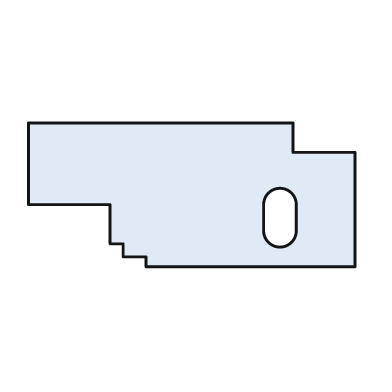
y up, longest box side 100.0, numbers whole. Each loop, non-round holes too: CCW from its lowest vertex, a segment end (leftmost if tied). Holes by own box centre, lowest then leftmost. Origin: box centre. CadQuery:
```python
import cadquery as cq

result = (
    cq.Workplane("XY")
    .moveTo(-14.0, -22.0)
    .lineTo(50.0, -22.0)
    .lineTo(50.0, 13.0)
    .lineTo(31.0, 13.0)
    .lineTo(31.0, 22.0)
    .lineTo(-50.0, 22.0)
    .lineTo(-50.0, -3.0)
    .lineTo(-25.0, -3.0)
    .lineTo(-25.0, -15.0)
    .lineTo(-21.0, -15.0)
    .lineTo(-21.0, -19.0)
    .lineTo(-14.0, -19.0)
    .close()
    .moveTo(22.0, -11.0)
    .threePointArc((27.0, -16.0), (32.0, -11.0))
    .lineTo(32.0, -3.0)
    .threePointArc((27.0, 2.0), (22.0, -3.0))
    .close()
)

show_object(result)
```